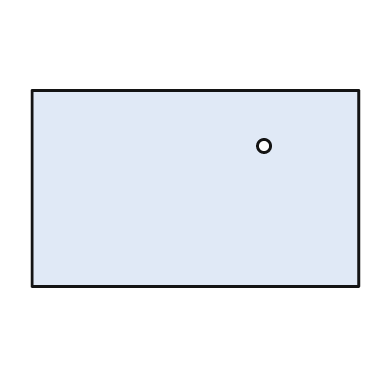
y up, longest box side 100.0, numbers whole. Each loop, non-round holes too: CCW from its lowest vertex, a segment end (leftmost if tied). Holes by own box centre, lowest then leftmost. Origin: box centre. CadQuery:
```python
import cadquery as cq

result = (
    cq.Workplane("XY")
    .moveTo(-50.0, -30.0)
    .lineTo(50.0, -30.0)
    .lineTo(50.0, 30.0)
    .lineTo(-50.0, 30.0)
    .close()
    .moveTo(21.0, 13.0)
    .circle(2.0)
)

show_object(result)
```